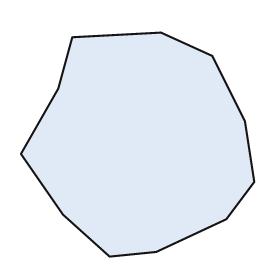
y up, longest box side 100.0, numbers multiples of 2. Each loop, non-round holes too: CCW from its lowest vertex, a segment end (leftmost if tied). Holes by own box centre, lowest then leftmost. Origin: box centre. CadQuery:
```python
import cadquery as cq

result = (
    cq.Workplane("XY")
    .moveTo(-12.0, -48.0)
    .lineTo(8.0, -46.0)
    .lineTo(38.0, -32.0)
    .lineTo(50.0, -16.0)
    .lineTo(46.0, 10.0)
    .lineTo(32.0, 38.0)
    .lineTo(10.0, 48.0)
    .lineTo(-28.0, 46.0)
    .lineTo(-34.0, 24.0)
    .lineTo(-50.0, -4.0)
    .lineTo(-32.0, -30.0)
    .close()
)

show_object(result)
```